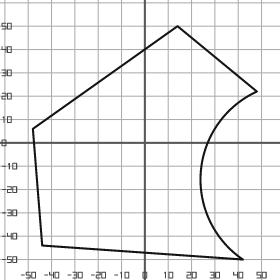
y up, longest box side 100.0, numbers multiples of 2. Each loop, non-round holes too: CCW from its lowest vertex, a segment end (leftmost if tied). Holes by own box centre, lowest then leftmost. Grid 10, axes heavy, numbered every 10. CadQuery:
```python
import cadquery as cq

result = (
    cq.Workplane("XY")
    .moveTo(42.0, -50.0)
    .threePointArc((24.0, -12.0), (48.0, 22.0))
    .lineTo(14.0, 50.0)
    .lineTo(-48.0, 6.0)
    .lineTo(-44.0, -44.0)
    .close()
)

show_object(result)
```